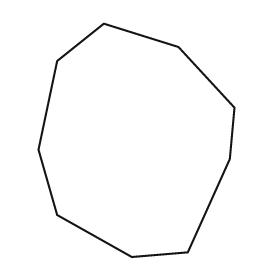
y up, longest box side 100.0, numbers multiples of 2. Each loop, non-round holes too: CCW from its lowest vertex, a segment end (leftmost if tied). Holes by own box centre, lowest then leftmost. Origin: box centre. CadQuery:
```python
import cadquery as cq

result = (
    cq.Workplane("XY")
    .moveTo(-2.0, -50.0)
    .lineTo(22.0, -48.0)
    .lineTo(40.0, -8.0)
    .lineTo(42.0, 14.0)
    .lineTo(18.0, 40.0)
    .lineTo(-14.0, 50.0)
    .lineTo(-34.0, 34.0)
    .lineTo(-42.0, -4.0)
    .lineTo(-34.0, -32.0)
    .close()
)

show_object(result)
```